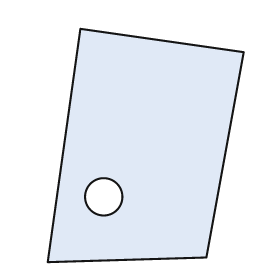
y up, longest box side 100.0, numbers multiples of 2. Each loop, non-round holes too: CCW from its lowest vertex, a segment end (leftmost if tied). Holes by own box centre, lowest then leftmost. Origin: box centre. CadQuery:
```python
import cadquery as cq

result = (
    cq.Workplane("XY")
    .moveTo(-42.0, -50.0)
    .lineTo(26.0, -48.0)
    .lineTo(42.0, 40.0)
    .lineTo(-28.0, 50.0)
    .close()
    .moveTo(-18.0, -22.0)
    .circle(8.0)
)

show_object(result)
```